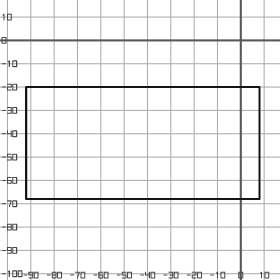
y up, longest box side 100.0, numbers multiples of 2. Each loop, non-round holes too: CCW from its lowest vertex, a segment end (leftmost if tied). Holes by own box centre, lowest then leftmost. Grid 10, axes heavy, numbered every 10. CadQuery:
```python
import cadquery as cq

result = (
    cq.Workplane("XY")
    .moveTo(-92.0, -68.0)
    .lineTo(8.0, -68.0)
    .lineTo(8.0, -20.0)
    .lineTo(-92.0, -20.0)
    .close()
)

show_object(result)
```